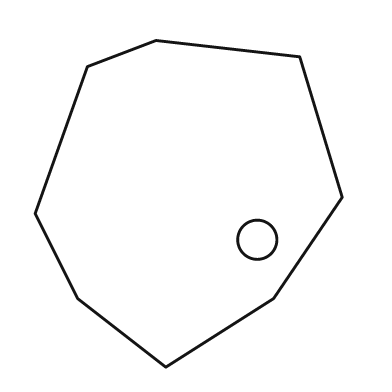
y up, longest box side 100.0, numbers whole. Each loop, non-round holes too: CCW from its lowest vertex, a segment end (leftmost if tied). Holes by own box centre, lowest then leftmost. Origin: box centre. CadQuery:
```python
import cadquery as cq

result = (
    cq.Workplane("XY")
    .moveTo(-7.0, -50.0)
    .lineTo(26.0, -29.0)
    .lineTo(47.0, 2.0)
    .lineTo(34.0, 45.0)
    .lineTo(-10.0, 50.0)
    .lineTo(-31.0, 42.0)
    .lineTo(-47.0, -3.0)
    .lineTo(-34.0, -29.0)
    .close()
    .moveTo(21.0, -11.0)
    .circle(6.0)
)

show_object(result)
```